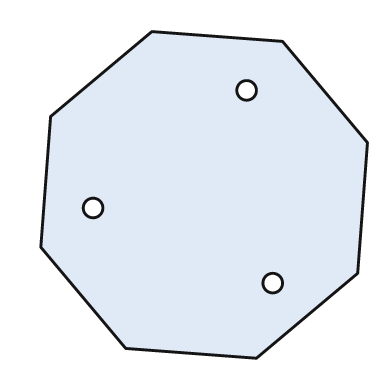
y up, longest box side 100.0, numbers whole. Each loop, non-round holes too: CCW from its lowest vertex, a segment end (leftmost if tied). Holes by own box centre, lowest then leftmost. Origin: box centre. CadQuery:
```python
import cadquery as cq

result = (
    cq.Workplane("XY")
    .moveTo(16.0, -50.0)
    .lineTo(47.0, -24.0)
    .lineTo(50.0, 16.0)
    .lineTo(24.0, 47.0)
    .lineTo(-16.0, 50.0)
    .lineTo(-47.0, 24.0)
    .lineTo(-50.0, -16.0)
    .lineTo(-24.0, -47.0)
    .close()
    .moveTo(21.0, -27.0)
    .circle(3.0)
    .moveTo(-34.0, -4.0)
    .circle(3.0)
    .moveTo(13.0, 32.0)
    .circle(3.0)
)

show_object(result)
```